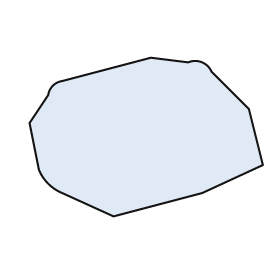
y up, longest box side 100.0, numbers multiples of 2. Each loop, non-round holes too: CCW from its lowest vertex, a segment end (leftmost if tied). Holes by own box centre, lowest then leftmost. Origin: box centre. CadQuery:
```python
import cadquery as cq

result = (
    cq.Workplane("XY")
    .moveTo(-14.0, -34.0)
    .lineTo(24.0, -24.0)
    .lineTo(50.0, -12.0)
    .lineTo(44.0, 12.0)
    .lineTo(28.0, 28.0)
    .threePointArc((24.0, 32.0), (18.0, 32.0))
    .lineTo(2.0, 34.0)
    .lineTo(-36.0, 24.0)
    .threePointArc((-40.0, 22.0), (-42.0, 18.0))
    .lineTo(-50.0, 6.0)
    .lineTo(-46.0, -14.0)
    .threePointArc((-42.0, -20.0), (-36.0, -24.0))
    .close()
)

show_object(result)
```